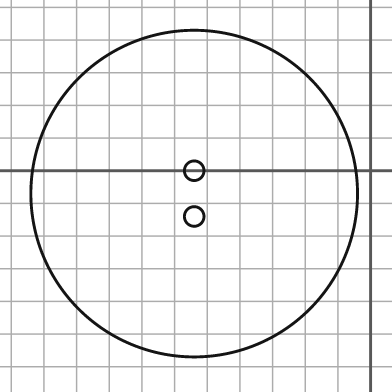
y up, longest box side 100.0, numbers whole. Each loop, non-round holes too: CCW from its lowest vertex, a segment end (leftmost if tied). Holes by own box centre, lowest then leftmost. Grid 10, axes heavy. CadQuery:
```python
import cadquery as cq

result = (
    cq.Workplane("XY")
    .moveTo(-54.0, -7.0)
    .circle(50.0)
    .moveTo(-54.0, -14.0)
    .circle(3.0)
    .moveTo(-54.0, 0.0)
    .circle(3.0)
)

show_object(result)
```